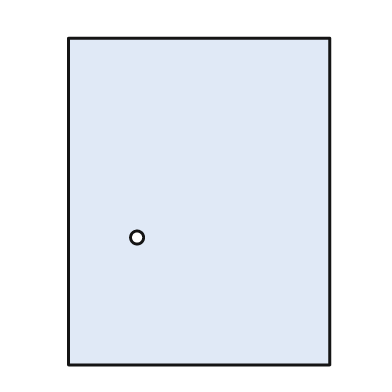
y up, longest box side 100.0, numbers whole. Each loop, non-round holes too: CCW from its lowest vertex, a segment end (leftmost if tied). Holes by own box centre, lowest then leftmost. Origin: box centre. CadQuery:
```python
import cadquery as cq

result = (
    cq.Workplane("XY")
    .moveTo(-40.0, -50.0)
    .lineTo(40.0, -50.0)
    .lineTo(40.0, 50.0)
    .lineTo(-40.0, 50.0)
    .close()
    .moveTo(-19.0, -11.0)
    .circle(2.0)
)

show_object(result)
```